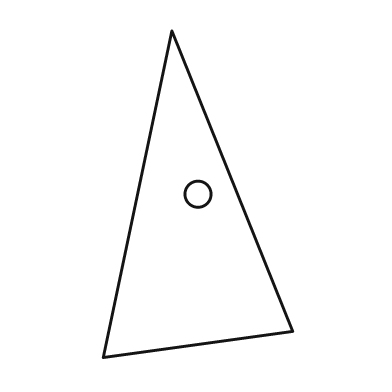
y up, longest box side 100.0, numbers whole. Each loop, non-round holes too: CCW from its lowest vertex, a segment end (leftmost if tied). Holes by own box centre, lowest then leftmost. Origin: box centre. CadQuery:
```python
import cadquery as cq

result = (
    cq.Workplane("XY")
    .moveTo(-29.0, -50.0)
    .lineTo(29.0, -42.0)
    .lineTo(-8.0, 50.0)
    .close()
    .moveTo(0.0, 0.0)
    .circle(4.0)
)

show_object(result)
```